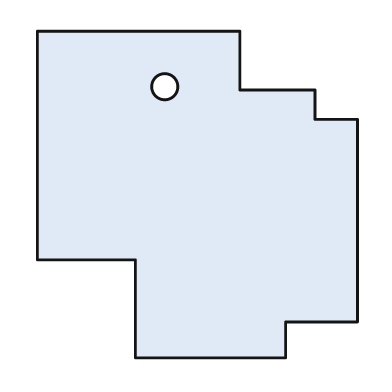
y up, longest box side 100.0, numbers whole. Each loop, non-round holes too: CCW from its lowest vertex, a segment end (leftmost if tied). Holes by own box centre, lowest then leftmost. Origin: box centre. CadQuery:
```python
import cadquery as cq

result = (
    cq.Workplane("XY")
    .moveTo(-19.0, -50.0)
    .lineTo(27.0, -50.0)
    .lineTo(27.0, -39.0)
    .lineTo(49.0, -39.0)
    .lineTo(49.0, 23.0)
    .lineTo(36.0, 23.0)
    .lineTo(36.0, 32.0)
    .lineTo(13.0, 32.0)
    .lineTo(13.0, 50.0)
    .lineTo(-49.0, 50.0)
    .lineTo(-49.0, -20.0)
    .lineTo(-19.0, -20.0)
    .close()
    .moveTo(-10.0, 33.0)
    .circle(4.0)
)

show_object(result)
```